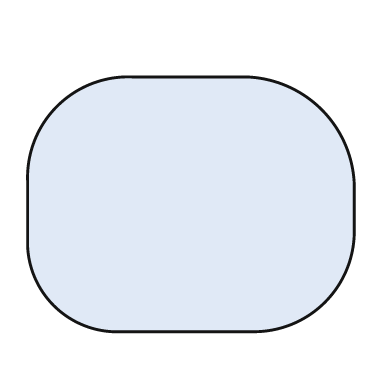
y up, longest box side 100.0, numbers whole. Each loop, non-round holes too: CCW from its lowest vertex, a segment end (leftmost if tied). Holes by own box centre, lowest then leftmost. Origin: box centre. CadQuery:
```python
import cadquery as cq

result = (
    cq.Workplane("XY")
    .moveTo(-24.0, -39.0)
    .lineTo(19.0, -39.0)
    .threePointArc((41.0, -30.0), (50.0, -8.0))
    .lineTo(50.0, 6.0)
    .threePointArc((40.0, 29.0), (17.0, 39.0))
    .lineTo(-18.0, 39.0)
    .threePointArc((-41.0, 30.0), (-50.0, 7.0))
    .lineTo(-50.0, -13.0)
    .threePointArc((-42.0, -31.0), (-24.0, -39.0))
    .close()
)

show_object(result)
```